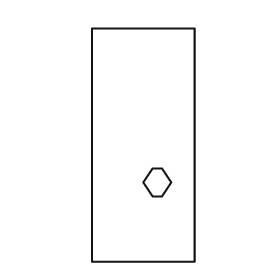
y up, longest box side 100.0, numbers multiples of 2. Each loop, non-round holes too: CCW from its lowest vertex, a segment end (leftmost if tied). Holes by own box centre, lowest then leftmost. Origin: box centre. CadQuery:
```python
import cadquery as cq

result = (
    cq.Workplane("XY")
    .moveTo(-22.0, -50.0)
    .lineTo(22.0, -50.0)
    .lineTo(22.0, 50.0)
    .lineTo(-22.0, 50.0)
    .close()
    .moveTo(4.0, -22.0)
    .lineTo(8.0, -22.0)
    .lineTo(12.0, -16.0)
    .lineTo(8.0, -10.0)
    .lineTo(4.0, -10.0)
    .lineTo(0.0, -16.0)
    .close()
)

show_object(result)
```